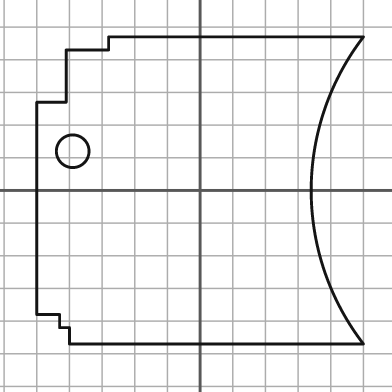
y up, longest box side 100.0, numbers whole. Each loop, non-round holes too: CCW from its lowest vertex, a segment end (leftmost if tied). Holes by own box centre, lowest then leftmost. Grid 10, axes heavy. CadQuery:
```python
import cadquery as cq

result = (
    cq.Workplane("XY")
    .moveTo(-40.0, -47.0)
    .lineTo(50.0, -47.0)
    .threePointArc((34.0, 0.0), (50.0, 47.0))
    .lineTo(-28.0, 47.0)
    .lineTo(-28.0, 43.0)
    .lineTo(-41.0, 43.0)
    .lineTo(-41.0, 27.0)
    .lineTo(-50.0, 27.0)
    .lineTo(-50.0, -38.0)
    .lineTo(-43.0, -38.0)
    .lineTo(-43.0, -42.0)
    .lineTo(-40.0, -42.0)
    .close()
    .moveTo(-39.0, 12.0)
    .circle(5.0)
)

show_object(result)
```